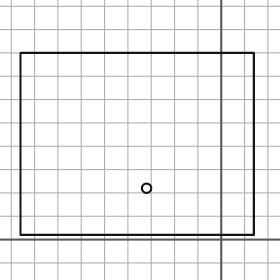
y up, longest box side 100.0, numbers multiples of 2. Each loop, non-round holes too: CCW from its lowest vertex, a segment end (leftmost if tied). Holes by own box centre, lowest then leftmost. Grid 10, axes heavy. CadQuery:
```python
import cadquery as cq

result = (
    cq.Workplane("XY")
    .moveTo(-86.0, 2.0)
    .lineTo(14.0, 2.0)
    .lineTo(14.0, 80.0)
    .lineTo(-86.0, 80.0)
    .close()
    .moveTo(-32.0, 22.0)
    .circle(2.0)
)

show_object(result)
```